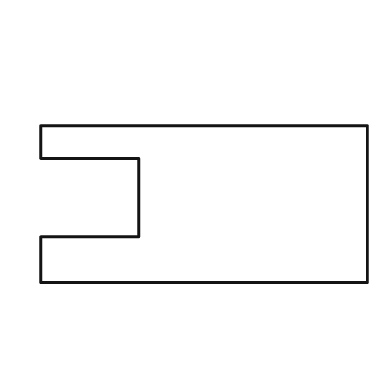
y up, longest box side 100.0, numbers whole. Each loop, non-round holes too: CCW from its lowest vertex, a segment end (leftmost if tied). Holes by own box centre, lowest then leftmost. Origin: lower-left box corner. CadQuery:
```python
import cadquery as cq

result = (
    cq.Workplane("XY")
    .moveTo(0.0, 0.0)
    .lineTo(100.0, 0.0)
    .lineTo(100.0, 48.0)
    .lineTo(0.0, 48.0)
    .lineTo(0.0, 38.0)
    .lineTo(30.0, 38.0)
    .lineTo(30.0, 14.0)
    .lineTo(0.0, 14.0)
    .close()
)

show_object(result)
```